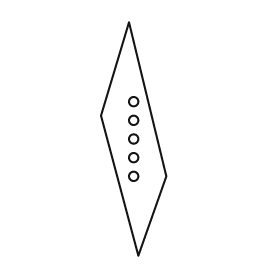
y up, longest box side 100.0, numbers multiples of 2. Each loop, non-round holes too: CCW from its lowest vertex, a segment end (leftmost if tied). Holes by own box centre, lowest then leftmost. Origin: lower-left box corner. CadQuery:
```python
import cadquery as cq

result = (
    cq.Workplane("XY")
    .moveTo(16.0, 0.0)
    .lineTo(28.0, 34.0)
    .lineTo(12.0, 100.0)
    .lineTo(0.0, 60.0)
    .close()
    .moveTo(14.0, 34.0)
    .circle(2.0)
    .moveTo(14.0, 42.0)
    .circle(2.0)
    .moveTo(14.0, 50.0)
    .circle(2.0)
    .moveTo(14.0, 58.0)
    .circle(2.0)
    .moveTo(14.0, 66.0)
    .circle(2.0)
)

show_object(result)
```